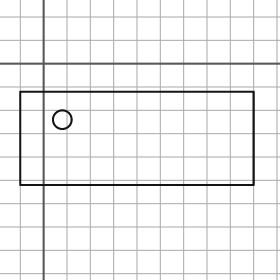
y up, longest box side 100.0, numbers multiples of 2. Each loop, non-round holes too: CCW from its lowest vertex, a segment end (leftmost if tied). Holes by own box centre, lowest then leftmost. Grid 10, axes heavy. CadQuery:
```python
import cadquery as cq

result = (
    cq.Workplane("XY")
    .moveTo(-10.0, -52.0)
    .lineTo(90.0, -52.0)
    .lineTo(90.0, -12.0)
    .lineTo(-10.0, -12.0)
    .close()
    .moveTo(8.0, -24.0)
    .circle(4.0)
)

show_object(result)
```